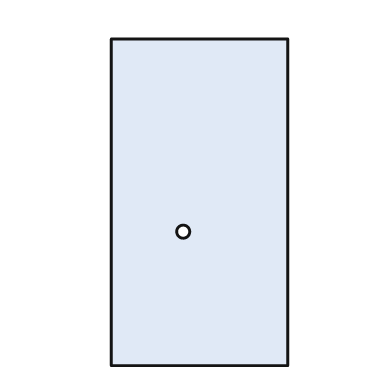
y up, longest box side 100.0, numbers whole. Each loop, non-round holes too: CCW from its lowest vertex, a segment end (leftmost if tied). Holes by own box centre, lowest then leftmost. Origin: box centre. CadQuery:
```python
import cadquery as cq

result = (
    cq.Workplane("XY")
    .moveTo(-27.0, -50.0)
    .lineTo(27.0, -50.0)
    .lineTo(27.0, 50.0)
    .lineTo(-27.0, 50.0)
    .close()
    .moveTo(-5.0, -9.0)
    .circle(2.0)
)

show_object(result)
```